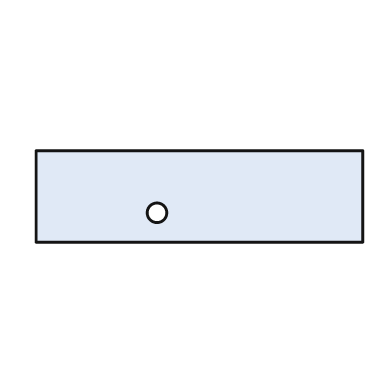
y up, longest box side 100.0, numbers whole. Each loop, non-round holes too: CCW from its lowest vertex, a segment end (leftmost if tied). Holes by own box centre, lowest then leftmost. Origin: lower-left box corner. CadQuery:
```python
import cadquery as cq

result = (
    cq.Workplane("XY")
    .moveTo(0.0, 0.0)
    .lineTo(100.0, 0.0)
    .lineTo(100.0, 28.0)
    .lineTo(0.0, 28.0)
    .close()
    .moveTo(37.0, 9.0)
    .circle(3.0)
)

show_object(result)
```